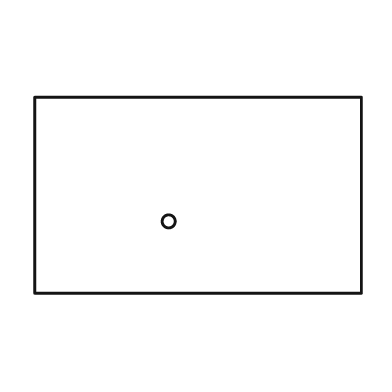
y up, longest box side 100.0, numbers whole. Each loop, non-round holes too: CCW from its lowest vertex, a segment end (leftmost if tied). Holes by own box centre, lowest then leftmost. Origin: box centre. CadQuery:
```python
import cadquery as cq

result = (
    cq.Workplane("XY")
    .moveTo(-50.0, -30.0)
    .lineTo(50.0, -30.0)
    .lineTo(50.0, 30.0)
    .lineTo(-50.0, 30.0)
    .close()
    .moveTo(-9.0, -8.0)
    .circle(2.0)
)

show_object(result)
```